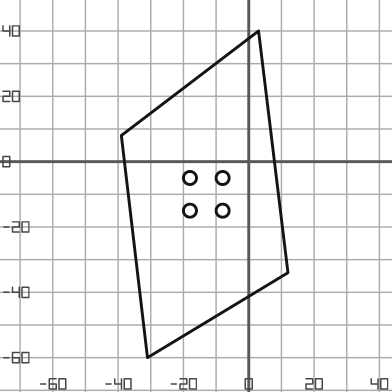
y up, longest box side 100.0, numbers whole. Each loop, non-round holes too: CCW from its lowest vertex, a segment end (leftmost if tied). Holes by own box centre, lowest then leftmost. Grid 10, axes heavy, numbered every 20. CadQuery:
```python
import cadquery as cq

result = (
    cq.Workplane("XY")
    .moveTo(-31.0, -60.0)
    .lineTo(12.0, -34.0)
    .lineTo(3.0, 40.0)
    .lineTo(-39.0, 8.0)
    .close()
    .moveTo(-18.0, -15.0)
    .circle(2.0)
    .moveTo(-8.0, -15.0)
    .circle(2.0)
    .moveTo(-18.0, -5.0)
    .circle(2.0)
    .moveTo(-8.0, -5.0)
    .circle(2.0)
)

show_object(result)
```